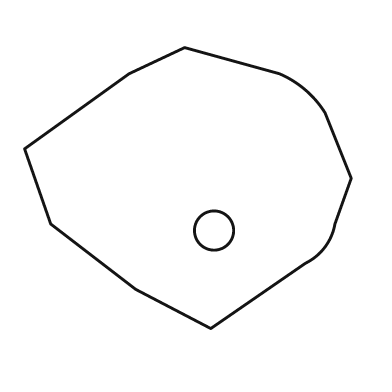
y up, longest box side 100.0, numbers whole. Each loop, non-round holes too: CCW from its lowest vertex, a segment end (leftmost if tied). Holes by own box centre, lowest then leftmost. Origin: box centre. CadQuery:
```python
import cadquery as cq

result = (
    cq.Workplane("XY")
    .moveTo(7.0, -43.0)
    .lineTo(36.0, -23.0)
    .threePointArc((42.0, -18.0), (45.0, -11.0))
    .lineTo(50.0, 3.0)
    .lineTo(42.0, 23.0)
    .threePointArc((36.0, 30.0), (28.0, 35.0))
    .lineTo(-1.0, 43.0)
    .lineTo(-18.0, 35.0)
    .lineTo(-50.0, 12.0)
    .lineTo(-42.0, -11.0)
    .lineTo(-16.0, -31.0)
    .close()
    .moveTo(8.0, -13.0)
    .circle(6.0)
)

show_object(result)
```